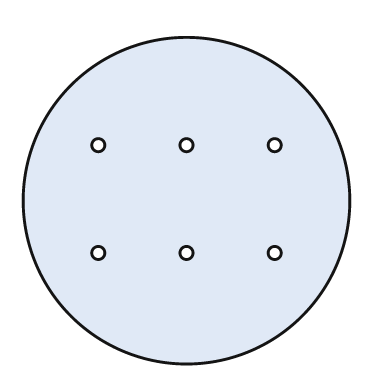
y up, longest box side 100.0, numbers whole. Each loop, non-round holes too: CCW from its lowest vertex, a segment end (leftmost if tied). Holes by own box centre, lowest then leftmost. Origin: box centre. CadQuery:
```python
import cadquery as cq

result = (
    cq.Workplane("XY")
    .moveTo(0.0, 0.0)
    .circle(50.0)
    .moveTo(-27.0, -16.0)
    .circle(2.0)
    .moveTo(0.0, -16.0)
    .circle(2.0)
    .moveTo(27.0, -16.0)
    .circle(2.0)
    .moveTo(-27.0, 17.0)
    .circle(2.0)
    .moveTo(0.0, 17.0)
    .circle(2.0)
    .moveTo(27.0, 17.0)
    .circle(2.0)
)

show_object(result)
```